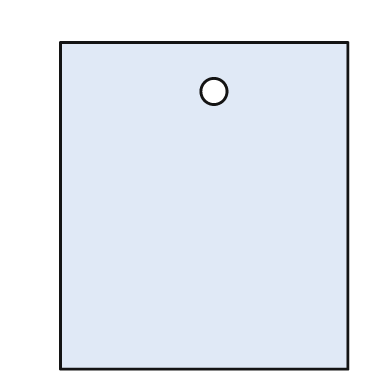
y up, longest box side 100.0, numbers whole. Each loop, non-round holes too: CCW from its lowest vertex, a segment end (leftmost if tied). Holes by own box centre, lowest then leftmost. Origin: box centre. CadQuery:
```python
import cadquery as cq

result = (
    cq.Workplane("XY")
    .moveTo(-44.0, -50.0)
    .lineTo(44.0, -50.0)
    .lineTo(44.0, 50.0)
    .lineTo(-44.0, 50.0)
    .close()
    .moveTo(3.0, 35.0)
    .circle(4.0)
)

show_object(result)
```